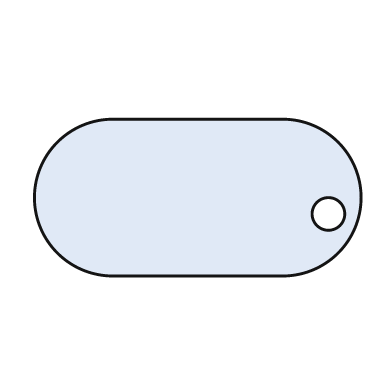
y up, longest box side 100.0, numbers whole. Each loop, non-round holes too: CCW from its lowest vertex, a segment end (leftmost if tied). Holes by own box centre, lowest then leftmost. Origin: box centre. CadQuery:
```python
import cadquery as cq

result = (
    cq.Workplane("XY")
    .moveTo(-26.0, -24.0)
    .lineTo(26.0, -24.0)
    .threePointArc((50.0, 0.0), (26.0, 24.0))
    .lineTo(-26.0, 24.0)
    .threePointArc((-50.0, 0.0), (-26.0, -24.0))
    .close()
    .moveTo(40.0, -5.0)
    .circle(5.0)
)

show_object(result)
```